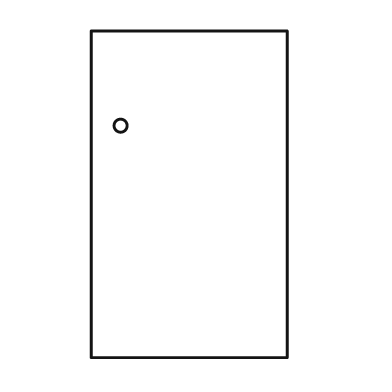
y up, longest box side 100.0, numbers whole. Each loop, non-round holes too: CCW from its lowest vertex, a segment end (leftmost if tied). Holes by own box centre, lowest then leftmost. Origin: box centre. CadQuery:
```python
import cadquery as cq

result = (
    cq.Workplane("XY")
    .moveTo(-30.0, -50.0)
    .lineTo(30.0, -50.0)
    .lineTo(30.0, 50.0)
    .lineTo(-30.0, 50.0)
    .close()
    .moveTo(-21.0, 21.0)
    .circle(2.0)
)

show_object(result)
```